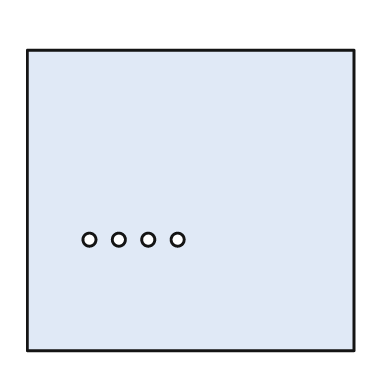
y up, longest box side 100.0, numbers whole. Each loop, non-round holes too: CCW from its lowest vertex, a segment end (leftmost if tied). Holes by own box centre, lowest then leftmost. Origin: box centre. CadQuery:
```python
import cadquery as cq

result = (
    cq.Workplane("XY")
    .moveTo(-50.0, -46.0)
    .lineTo(50.0, -46.0)
    .lineTo(50.0, 46.0)
    .lineTo(-50.0, 46.0)
    .close()
    .moveTo(-31.0, -12.0)
    .circle(2.0)
    .moveTo(-22.0, -12.0)
    .circle(2.0)
    .moveTo(-13.0, -12.0)
    .circle(2.0)
    .moveTo(-4.0, -12.0)
    .circle(2.0)
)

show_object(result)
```